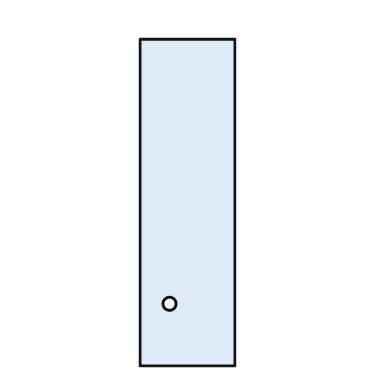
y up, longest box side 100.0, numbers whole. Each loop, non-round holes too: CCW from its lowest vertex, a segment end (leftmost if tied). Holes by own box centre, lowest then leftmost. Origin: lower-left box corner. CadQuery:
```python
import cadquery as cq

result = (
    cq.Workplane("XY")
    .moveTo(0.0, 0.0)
    .lineTo(29.0, 0.0)
    .lineTo(29.0, 100.0)
    .lineTo(0.0, 100.0)
    .close()
    .moveTo(9.0, 19.0)
    .circle(2.0)
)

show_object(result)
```